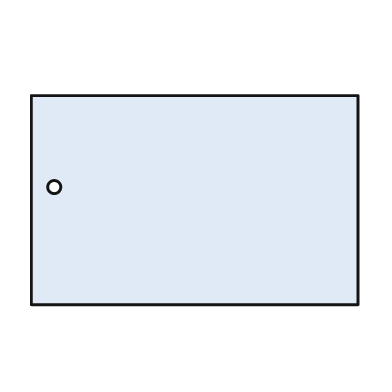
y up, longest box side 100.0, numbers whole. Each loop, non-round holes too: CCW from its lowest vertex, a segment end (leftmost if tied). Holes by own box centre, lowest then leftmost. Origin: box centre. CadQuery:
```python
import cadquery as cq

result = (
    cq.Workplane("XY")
    .moveTo(-50.0, -32.0)
    .lineTo(50.0, -32.0)
    .lineTo(50.0, 32.0)
    .lineTo(-50.0, 32.0)
    .close()
    .moveTo(-43.0, 4.0)
    .circle(2.0)
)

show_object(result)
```